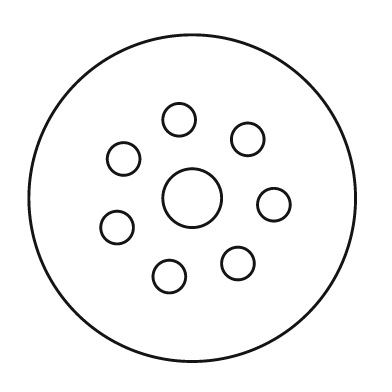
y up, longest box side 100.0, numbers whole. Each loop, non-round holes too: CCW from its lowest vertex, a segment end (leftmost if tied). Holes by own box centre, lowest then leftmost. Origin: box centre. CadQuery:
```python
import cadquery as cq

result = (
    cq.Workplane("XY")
    .moveTo(0.0, 0.0)
    .circle(50.0)
    .moveTo(-7.0, -24.0)
    .circle(5.0)
    .moveTo(14.0, -20.0)
    .circle(5.0)
    .moveTo(-23.0, -9.0)
    .circle(5.0)
    .moveTo(25.0, -2.0)
    .circle(5.0)
    .moveTo(0.0, 0.0)
    .circle(9.0)
    .moveTo(-21.0, 12.0)
    .circle(5.0)
    .moveTo(17.0, 18.0)
    .circle(5.0)
    .moveTo(-4.0, 24.0)
    .circle(5.0)
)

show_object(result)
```